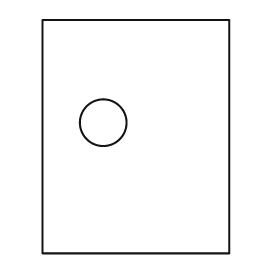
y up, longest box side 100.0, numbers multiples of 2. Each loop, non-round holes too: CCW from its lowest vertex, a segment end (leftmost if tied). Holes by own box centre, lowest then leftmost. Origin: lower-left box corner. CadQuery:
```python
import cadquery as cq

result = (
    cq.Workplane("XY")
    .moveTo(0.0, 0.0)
    .lineTo(80.0, 0.0)
    .lineTo(80.0, 100.0)
    .lineTo(0.0, 100.0)
    .close()
    .moveTo(26.0, 56.0)
    .circle(10.0)
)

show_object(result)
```